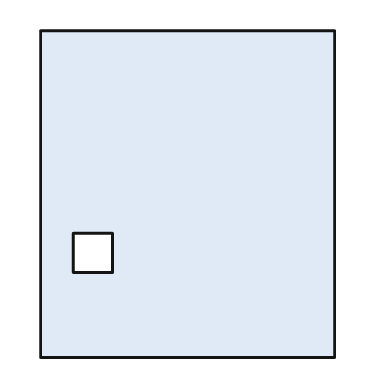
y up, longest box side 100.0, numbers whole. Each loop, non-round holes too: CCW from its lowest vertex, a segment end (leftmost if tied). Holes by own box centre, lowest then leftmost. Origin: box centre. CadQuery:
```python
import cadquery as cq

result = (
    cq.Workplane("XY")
    .moveTo(-45.0, -50.0)
    .lineTo(45.0, -50.0)
    .lineTo(45.0, 50.0)
    .lineTo(-45.0, 50.0)
    .close()
    .moveTo(-35.0, -24.0)
    .lineTo(-23.0, -24.0)
    .lineTo(-23.0, -12.0)
    .lineTo(-35.0, -12.0)
    .close()
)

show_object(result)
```